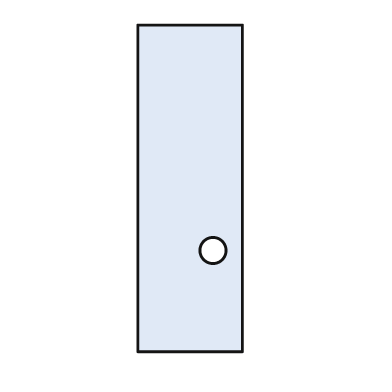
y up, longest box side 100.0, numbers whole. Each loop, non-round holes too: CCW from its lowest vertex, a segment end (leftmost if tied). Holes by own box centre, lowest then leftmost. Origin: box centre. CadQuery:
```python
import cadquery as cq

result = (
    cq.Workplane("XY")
    .moveTo(-16.0, -50.0)
    .lineTo(16.0, -50.0)
    .lineTo(16.0, 50.0)
    .lineTo(-16.0, 50.0)
    .close()
    .moveTo(7.0, -19.0)
    .circle(4.0)
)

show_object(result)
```